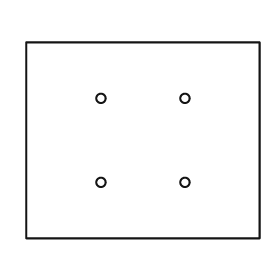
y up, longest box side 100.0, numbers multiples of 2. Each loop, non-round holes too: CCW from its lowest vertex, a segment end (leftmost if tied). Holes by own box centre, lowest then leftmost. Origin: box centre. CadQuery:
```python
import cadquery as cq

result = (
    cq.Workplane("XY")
    .moveTo(-50.0, -42.0)
    .lineTo(50.0, -42.0)
    .lineTo(50.0, 42.0)
    .lineTo(-50.0, 42.0)
    .close()
    .moveTo(-18.0, -18.0)
    .circle(2.0)
    .moveTo(18.0, -18.0)
    .circle(2.0)
    .moveTo(-18.0, 18.0)
    .circle(2.0)
    .moveTo(18.0, 18.0)
    .circle(2.0)
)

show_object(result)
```